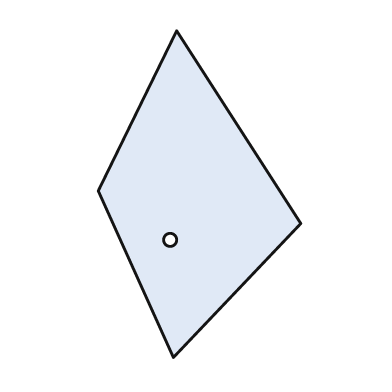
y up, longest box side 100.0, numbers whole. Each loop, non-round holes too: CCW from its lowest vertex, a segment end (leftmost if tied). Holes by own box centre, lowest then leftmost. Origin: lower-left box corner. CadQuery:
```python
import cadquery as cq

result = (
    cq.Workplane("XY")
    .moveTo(23.0, 0.0)
    .lineTo(62.0, 41.0)
    .lineTo(24.0, 100.0)
    .lineTo(0.0, 51.0)
    .close()
    .moveTo(22.0, 36.0)
    .circle(2.0)
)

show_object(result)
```